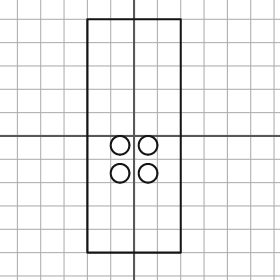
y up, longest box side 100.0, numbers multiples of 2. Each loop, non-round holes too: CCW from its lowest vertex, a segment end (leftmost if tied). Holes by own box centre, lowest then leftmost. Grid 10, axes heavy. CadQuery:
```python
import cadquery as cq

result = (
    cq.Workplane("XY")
    .moveTo(-20.0, -50.0)
    .lineTo(20.0, -50.0)
    .lineTo(20.0, 50.0)
    .lineTo(-20.0, 50.0)
    .close()
    .moveTo(-6.0, -16.0)
    .circle(4.0)
    .moveTo(6.0, -16.0)
    .circle(4.0)
    .moveTo(-6.0, -4.0)
    .circle(4.0)
    .moveTo(6.0, -4.0)
    .circle(4.0)
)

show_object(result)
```